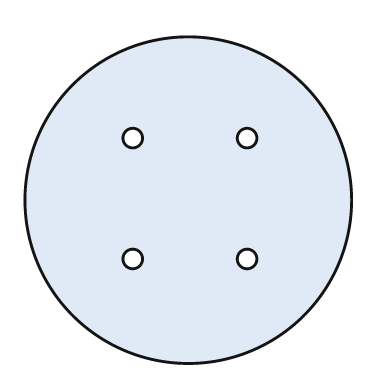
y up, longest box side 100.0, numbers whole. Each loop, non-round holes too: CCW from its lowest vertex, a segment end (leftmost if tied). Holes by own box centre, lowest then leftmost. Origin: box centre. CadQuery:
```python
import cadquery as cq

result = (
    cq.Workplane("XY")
    .moveTo(0.0, 0.0)
    .circle(50.0)
    .moveTo(-17.0, -18.0)
    .circle(3.0)
    .moveTo(18.0, -18.0)
    .circle(3.0)
    .moveTo(-17.0, 19.0)
    .circle(3.0)
    .moveTo(18.0, 19.0)
    .circle(3.0)
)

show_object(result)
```